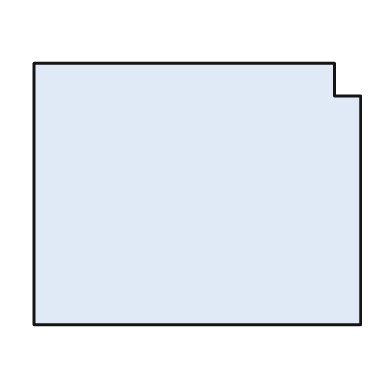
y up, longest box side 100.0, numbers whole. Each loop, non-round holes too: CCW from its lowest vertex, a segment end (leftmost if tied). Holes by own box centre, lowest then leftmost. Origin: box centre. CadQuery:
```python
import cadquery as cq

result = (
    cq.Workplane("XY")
    .moveTo(-50.0, -40.0)
    .lineTo(50.0, -40.0)
    .lineTo(50.0, 30.0)
    .lineTo(42.0, 30.0)
    .lineTo(42.0, 40.0)
    .lineTo(-50.0, 40.0)
    .close()
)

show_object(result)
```